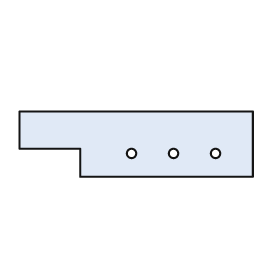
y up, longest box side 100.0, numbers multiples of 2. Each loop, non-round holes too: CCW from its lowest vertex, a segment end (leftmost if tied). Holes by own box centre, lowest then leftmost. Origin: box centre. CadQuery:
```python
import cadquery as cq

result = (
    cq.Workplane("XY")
    .moveTo(-24.0, -14.0)
    .lineTo(50.0, -14.0)
    .lineTo(50.0, 14.0)
    .lineTo(-50.0, 14.0)
    .lineTo(-50.0, -2.0)
    .lineTo(-24.0, -2.0)
    .close()
    .moveTo(-2.0, -4.0)
    .circle(2.0)
    .moveTo(16.0, -4.0)
    .circle(2.0)
    .moveTo(34.0, -4.0)
    .circle(2.0)
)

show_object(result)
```